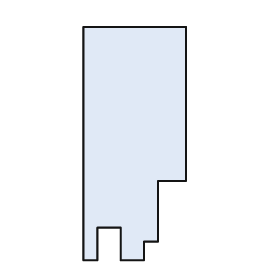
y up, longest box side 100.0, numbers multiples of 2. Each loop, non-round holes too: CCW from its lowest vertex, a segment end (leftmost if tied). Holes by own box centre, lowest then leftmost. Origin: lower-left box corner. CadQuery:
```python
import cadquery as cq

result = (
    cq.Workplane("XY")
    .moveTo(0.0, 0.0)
    .lineTo(6.0, 0.0)
    .lineTo(6.0, 14.0)
    .lineTo(16.0, 14.0)
    .lineTo(16.0, 0.0)
    .lineTo(26.0, 0.0)
    .lineTo(26.0, 8.0)
    .lineTo(32.0, 8.0)
    .lineTo(32.0, 34.0)
    .lineTo(44.0, 34.0)
    .lineTo(44.0, 100.0)
    .lineTo(0.0, 100.0)
    .close()
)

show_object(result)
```